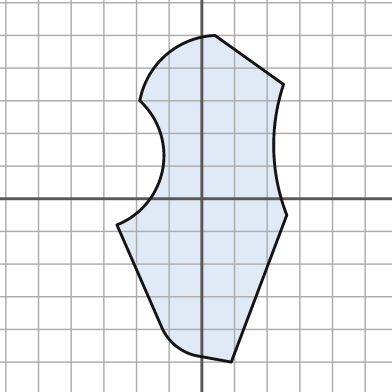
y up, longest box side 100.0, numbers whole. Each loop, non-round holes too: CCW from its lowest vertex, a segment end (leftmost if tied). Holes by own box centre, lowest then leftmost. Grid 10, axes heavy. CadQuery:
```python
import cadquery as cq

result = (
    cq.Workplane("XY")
    .moveTo(9.0, -50.0)
    .lineTo(26.0, -5.0)
    .threePointArc((22.0, 15.0), (25.0, 35.0))
    .lineTo(4.0, 50.0)
    .threePointArc((-11.0, 44.0), (-19.0, 30.0))
    .threePointArc((-12.0, 9.0), (-26.0, -8.0))
    .lineTo(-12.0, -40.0)
    .threePointArc((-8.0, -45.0), (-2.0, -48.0))
    .close()
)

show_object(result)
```